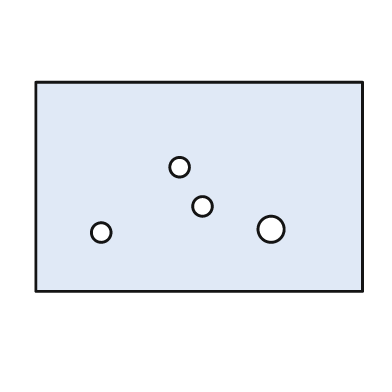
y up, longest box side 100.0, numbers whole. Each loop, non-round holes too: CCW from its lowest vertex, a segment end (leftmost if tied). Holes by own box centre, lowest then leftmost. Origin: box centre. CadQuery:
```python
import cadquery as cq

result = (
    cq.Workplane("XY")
    .moveTo(-50.0, -32.0)
    .lineTo(50.0, -32.0)
    .lineTo(50.0, 32.0)
    .lineTo(-50.0, 32.0)
    .close()
    .moveTo(-30.0, -14.0)
    .circle(3.0)
    .moveTo(22.0, -13.0)
    .circle(4.0)
    .moveTo(1.0, -6.0)
    .circle(3.0)
    .moveTo(-6.0, 6.0)
    .circle(3.0)
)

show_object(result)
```